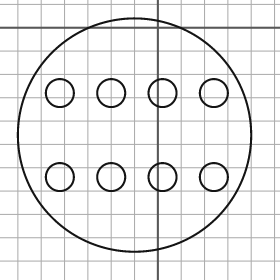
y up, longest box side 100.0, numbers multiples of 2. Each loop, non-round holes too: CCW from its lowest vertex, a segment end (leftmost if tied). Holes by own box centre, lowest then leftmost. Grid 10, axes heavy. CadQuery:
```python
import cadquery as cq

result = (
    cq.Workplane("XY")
    .moveTo(-10.0, -46.0)
    .circle(50.0)
    .moveTo(-42.0, -64.0)
    .circle(6.0)
    .moveTo(-20.0, -64.0)
    .circle(6.0)
    .moveTo(2.0, -64.0)
    .circle(6.0)
    .moveTo(24.0, -64.0)
    .circle(6.0)
    .moveTo(-42.0, -28.0)
    .circle(6.0)
    .moveTo(-20.0, -28.0)
    .circle(6.0)
    .moveTo(2.0, -28.0)
    .circle(6.0)
    .moveTo(24.0, -28.0)
    .circle(6.0)
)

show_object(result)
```